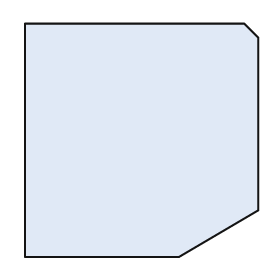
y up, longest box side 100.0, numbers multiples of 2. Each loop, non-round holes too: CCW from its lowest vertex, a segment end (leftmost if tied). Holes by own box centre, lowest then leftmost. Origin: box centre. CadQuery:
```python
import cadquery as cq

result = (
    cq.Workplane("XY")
    .moveTo(-50.0, -50.0)
    .lineTo(16.0, -50.0)
    .lineTo(50.0, -30.0)
    .lineTo(50.0, 44.0)
    .lineTo(44.0, 50.0)
    .lineTo(-50.0, 50.0)
    .close()
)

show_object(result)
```